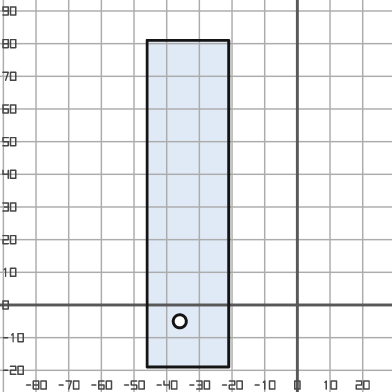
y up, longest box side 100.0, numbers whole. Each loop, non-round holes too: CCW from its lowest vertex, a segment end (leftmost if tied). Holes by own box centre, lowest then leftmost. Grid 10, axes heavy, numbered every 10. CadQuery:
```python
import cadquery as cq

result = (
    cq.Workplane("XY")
    .moveTo(-46.0, -19.0)
    .lineTo(-21.0, -19.0)
    .lineTo(-21.0, 81.0)
    .lineTo(-46.0, 81.0)
    .close()
    .moveTo(-36.0, -5.0)
    .circle(2.0)
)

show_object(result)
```